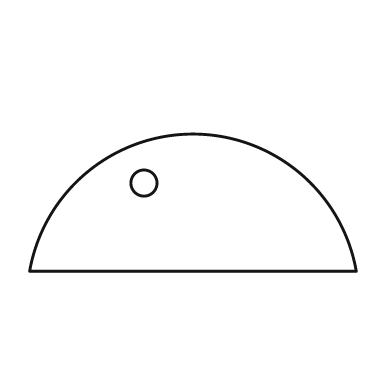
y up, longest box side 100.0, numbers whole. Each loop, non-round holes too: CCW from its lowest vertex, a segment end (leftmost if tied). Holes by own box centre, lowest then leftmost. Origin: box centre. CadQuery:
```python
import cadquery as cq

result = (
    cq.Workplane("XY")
    .moveTo(-50.0, -21.0)
    .lineTo(50.0, -21.0)
    .threePointArc((0.0, 21.0), (-50.0, -21.0))
    .close()
    .moveTo(-15.0, 6.0)
    .circle(4.0)
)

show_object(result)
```